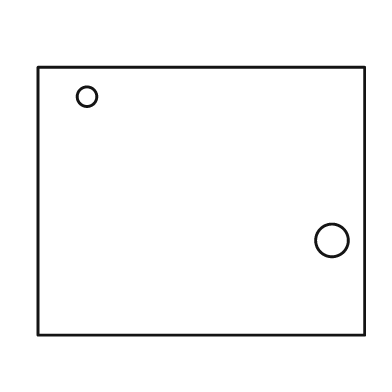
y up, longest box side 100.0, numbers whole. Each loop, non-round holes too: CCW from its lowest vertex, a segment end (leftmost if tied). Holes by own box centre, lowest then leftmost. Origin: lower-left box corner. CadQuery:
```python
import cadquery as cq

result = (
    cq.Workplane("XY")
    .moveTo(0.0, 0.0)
    .lineTo(100.0, 0.0)
    .lineTo(100.0, 82.0)
    .lineTo(0.0, 82.0)
    .close()
    .moveTo(90.0, 29.0)
    .circle(5.0)
    .moveTo(15.0, 73.0)
    .circle(3.0)
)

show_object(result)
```